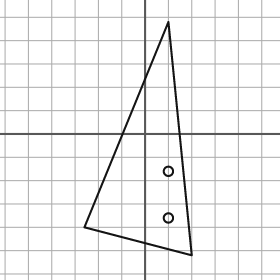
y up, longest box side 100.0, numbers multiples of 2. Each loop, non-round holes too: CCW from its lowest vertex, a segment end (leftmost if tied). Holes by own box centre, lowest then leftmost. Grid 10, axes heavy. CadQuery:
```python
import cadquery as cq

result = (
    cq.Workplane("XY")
    .moveTo(20.0, -52.0)
    .lineTo(10.0, 48.0)
    .lineTo(-26.0, -40.0)
    .close()
    .moveTo(10.0, -36.0)
    .circle(2.0)
    .moveTo(10.0, -16.0)
    .circle(2.0)
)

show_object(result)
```